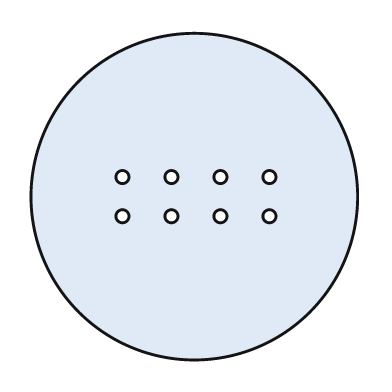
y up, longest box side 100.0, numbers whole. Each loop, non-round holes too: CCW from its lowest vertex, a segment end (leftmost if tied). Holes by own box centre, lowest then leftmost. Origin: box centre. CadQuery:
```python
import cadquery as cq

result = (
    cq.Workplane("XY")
    .moveTo(0.0, 0.0)
    .circle(50.0)
    .moveTo(-22.0, -6.0)
    .circle(2.0)
    .moveTo(-7.0, -6.0)
    .circle(2.0)
    .moveTo(8.0, -6.0)
    .circle(2.0)
    .moveTo(23.0, -6.0)
    .circle(2.0)
    .moveTo(-22.0, 6.0)
    .circle(2.0)
    .moveTo(-7.0, 6.0)
    .circle(2.0)
    .moveTo(8.0, 6.0)
    .circle(2.0)
    .moveTo(23.0, 6.0)
    .circle(2.0)
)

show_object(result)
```